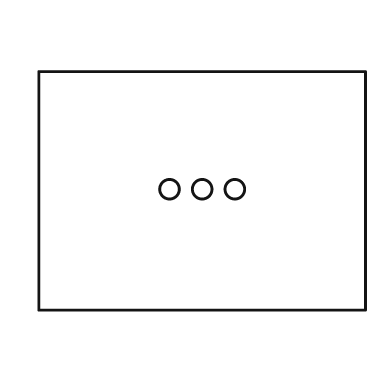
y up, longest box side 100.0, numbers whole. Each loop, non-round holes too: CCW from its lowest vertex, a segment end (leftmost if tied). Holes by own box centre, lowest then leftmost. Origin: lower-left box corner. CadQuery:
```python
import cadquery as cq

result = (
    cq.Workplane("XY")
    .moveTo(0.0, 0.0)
    .lineTo(100.0, 0.0)
    .lineTo(100.0, 73.0)
    .lineTo(0.0, 73.0)
    .close()
    .moveTo(40.0, 37.0)
    .circle(3.0)
    .moveTo(50.0, 37.0)
    .circle(3.0)
    .moveTo(60.0, 37.0)
    .circle(3.0)
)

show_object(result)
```